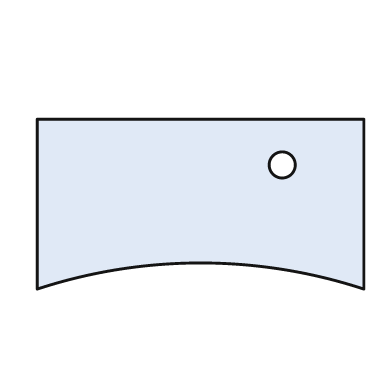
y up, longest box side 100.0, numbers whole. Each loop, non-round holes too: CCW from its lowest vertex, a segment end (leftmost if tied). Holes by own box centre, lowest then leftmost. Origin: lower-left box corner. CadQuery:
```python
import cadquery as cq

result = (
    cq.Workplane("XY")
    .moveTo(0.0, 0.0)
    .threePointArc((50.0, 8.0), (100.0, 0.0))
    .lineTo(100.0, 52.0)
    .lineTo(0.0, 52.0)
    .close()
    .moveTo(75.0, 38.0)
    .circle(4.0)
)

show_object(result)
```